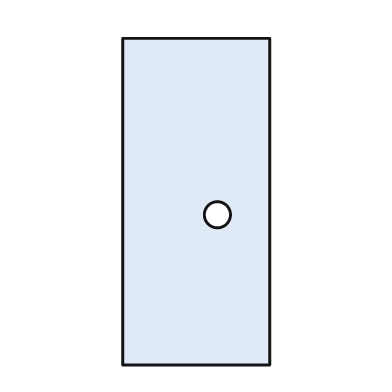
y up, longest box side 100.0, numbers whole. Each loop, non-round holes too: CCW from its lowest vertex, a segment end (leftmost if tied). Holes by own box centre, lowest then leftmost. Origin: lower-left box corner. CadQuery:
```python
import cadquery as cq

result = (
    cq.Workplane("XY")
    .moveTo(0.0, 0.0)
    .lineTo(45.0, 0.0)
    .lineTo(45.0, 100.0)
    .lineTo(0.0, 100.0)
    .close()
    .moveTo(29.0, 46.0)
    .circle(4.0)
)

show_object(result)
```